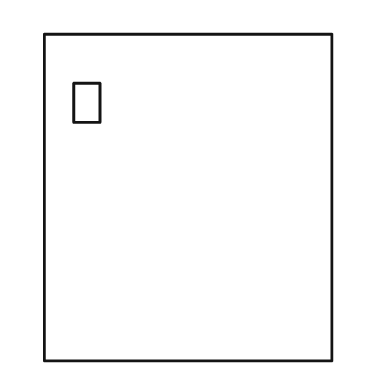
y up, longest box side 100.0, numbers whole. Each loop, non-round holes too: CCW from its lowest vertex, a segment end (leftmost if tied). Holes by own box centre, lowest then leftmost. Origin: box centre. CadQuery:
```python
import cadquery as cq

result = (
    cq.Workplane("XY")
    .moveTo(-44.0, -50.0)
    .lineTo(44.0, -50.0)
    .lineTo(44.0, 50.0)
    .lineTo(-44.0, 50.0)
    .close()
    .moveTo(-35.0, 23.0)
    .lineTo(-27.0, 23.0)
    .lineTo(-27.0, 35.0)
    .lineTo(-35.0, 35.0)
    .close()
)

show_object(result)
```